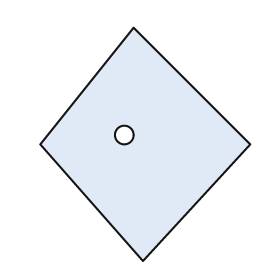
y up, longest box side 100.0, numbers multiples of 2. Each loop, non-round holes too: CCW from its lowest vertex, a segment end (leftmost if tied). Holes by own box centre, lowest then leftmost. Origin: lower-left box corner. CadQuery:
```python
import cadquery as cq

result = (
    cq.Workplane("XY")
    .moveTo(44.0, 0.0)
    .lineTo(90.0, 50.0)
    .lineTo(40.0, 100.0)
    .lineTo(0.0, 50.0)
    .close()
    .moveTo(36.0, 54.0)
    .circle(4.0)
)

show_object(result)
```